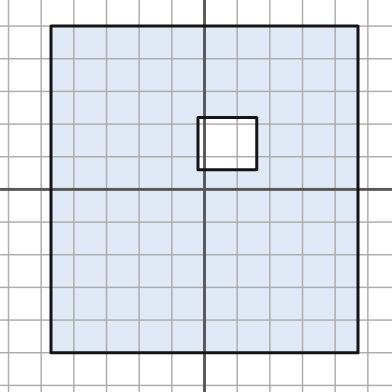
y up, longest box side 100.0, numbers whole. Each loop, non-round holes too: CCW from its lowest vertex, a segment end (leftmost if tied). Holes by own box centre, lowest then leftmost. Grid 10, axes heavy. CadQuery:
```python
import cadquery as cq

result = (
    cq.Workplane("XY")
    .moveTo(-47.0, -50.0)
    .lineTo(47.0, -50.0)
    .lineTo(47.0, 50.0)
    .lineTo(-47.0, 50.0)
    .close()
    .moveTo(-2.0, 6.0)
    .lineTo(16.0, 6.0)
    .lineTo(16.0, 22.0)
    .lineTo(-2.0, 22.0)
    .close()
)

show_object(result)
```